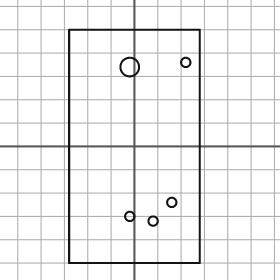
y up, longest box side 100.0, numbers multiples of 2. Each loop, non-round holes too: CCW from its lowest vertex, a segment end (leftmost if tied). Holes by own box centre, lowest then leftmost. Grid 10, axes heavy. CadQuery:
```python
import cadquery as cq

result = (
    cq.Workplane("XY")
    .moveTo(-28.0, -50.0)
    .lineTo(28.0, -50.0)
    .lineTo(28.0, 50.0)
    .lineTo(-28.0, 50.0)
    .close()
    .moveTo(8.0, -32.0)
    .circle(2.0)
    .moveTo(-2.0, -30.0)
    .circle(2.0)
    .moveTo(16.0, -24.0)
    .circle(2.0)
    .moveTo(-2.0, 34.0)
    .circle(4.0)
    .moveTo(22.0, 36.0)
    .circle(2.0)
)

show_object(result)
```